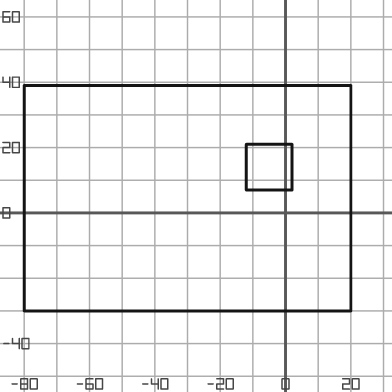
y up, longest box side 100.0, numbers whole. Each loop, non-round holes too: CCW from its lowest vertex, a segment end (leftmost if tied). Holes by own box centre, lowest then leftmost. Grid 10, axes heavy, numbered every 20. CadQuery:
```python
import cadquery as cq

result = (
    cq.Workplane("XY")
    .moveTo(-80.0, -30.0)
    .lineTo(20.0, -30.0)
    .lineTo(20.0, 39.0)
    .lineTo(-80.0, 39.0)
    .close()
    .moveTo(-12.0, 7.0)
    .lineTo(2.0, 7.0)
    .lineTo(2.0, 21.0)
    .lineTo(-12.0, 21.0)
    .close()
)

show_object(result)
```